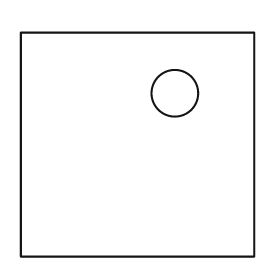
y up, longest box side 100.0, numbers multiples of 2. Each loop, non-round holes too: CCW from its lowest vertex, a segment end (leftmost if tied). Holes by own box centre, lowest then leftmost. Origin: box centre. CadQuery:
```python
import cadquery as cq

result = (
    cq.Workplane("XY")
    .moveTo(-50.0, -48.0)
    .lineTo(50.0, -48.0)
    .lineTo(50.0, 48.0)
    .lineTo(-50.0, 48.0)
    .close()
    .moveTo(16.0, 22.0)
    .circle(10.0)
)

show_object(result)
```